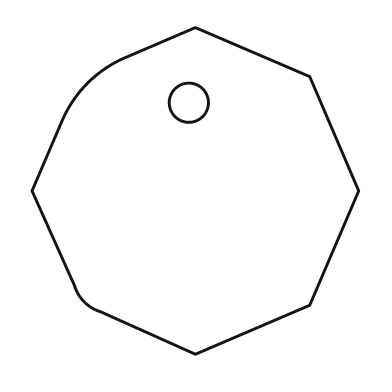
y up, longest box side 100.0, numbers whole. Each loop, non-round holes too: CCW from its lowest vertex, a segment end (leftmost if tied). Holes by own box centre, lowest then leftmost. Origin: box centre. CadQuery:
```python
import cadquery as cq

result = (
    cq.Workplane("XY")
    .moveTo(0.0, -50.0)
    .lineTo(35.0, -35.0)
    .lineTo(50.0, 0.0)
    .lineTo(35.0, 35.0)
    .lineTo(0.0, 50.0)
    .lineTo(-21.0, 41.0)
    .threePointArc((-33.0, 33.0), (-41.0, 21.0))
    .lineTo(-50.0, 0.0)
    .lineTo(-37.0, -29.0)
    .threePointArc((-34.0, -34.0), (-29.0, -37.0))
    .close()
    .moveTo(-2.0, 27.0)
    .circle(6.0)
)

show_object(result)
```